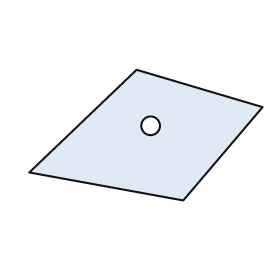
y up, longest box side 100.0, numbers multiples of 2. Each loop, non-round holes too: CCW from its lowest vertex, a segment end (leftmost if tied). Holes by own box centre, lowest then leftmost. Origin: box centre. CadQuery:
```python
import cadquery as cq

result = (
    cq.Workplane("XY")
    .moveTo(16.0, -28.0)
    .lineTo(50.0, 12.0)
    .lineTo(-4.0, 28.0)
    .lineTo(-50.0, -16.0)
    .close()
    .moveTo(2.0, 4.0)
    .circle(4.0)
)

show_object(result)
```